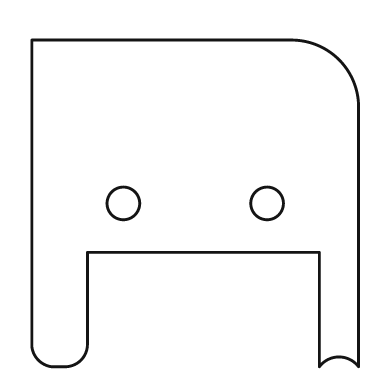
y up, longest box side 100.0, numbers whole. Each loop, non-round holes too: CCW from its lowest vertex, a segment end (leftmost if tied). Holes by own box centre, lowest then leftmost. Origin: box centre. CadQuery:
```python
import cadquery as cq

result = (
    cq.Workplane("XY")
    .moveTo(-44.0, -50.0)
    .lineTo(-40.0, -50.0)
    .threePointArc((-35.0, -48.0), (-33.0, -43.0))
    .lineTo(-33.0, -15.0)
    .lineTo(38.0, -15.0)
    .lineTo(38.0, -50.0)
    .threePointArc((44.0, -47.0), (50.0, -50.0))
    .lineTo(50.0, 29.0)
    .threePointArc((44.0, 44.0), (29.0, 50.0))
    .lineTo(-50.0, 50.0)
    .lineTo(-50.0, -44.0)
    .threePointArc((-48.0, -48.0), (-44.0, -50.0))
    .close()
    .moveTo(-22.0, 0.0)
    .circle(5.0)
    .moveTo(22.0, 0.0)
    .circle(5.0)
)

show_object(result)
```